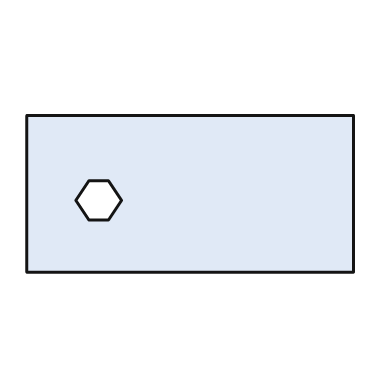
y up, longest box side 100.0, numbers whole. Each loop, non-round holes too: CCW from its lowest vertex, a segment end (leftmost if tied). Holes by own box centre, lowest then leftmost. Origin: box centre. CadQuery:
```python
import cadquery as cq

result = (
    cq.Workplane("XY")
    .moveTo(-50.0, -24.0)
    .lineTo(50.0, -24.0)
    .lineTo(50.0, 24.0)
    .lineTo(-50.0, 24.0)
    .close()
    .moveTo(-31.0, -8.0)
    .lineTo(-25.0, -8.0)
    .lineTo(-21.0, -2.0)
    .lineTo(-25.0, 4.0)
    .lineTo(-31.0, 4.0)
    .lineTo(-35.0, -2.0)
    .close()
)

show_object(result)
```